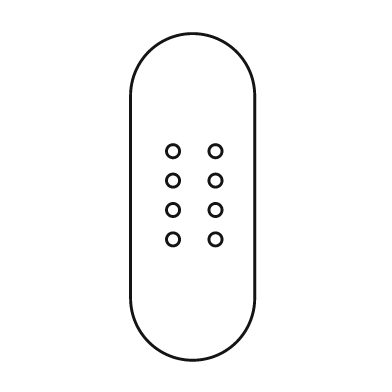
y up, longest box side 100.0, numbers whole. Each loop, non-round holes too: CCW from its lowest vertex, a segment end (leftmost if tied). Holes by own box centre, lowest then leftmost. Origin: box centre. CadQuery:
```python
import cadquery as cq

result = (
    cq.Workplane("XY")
    .moveTo(-19.0, -31.0)
    .threePointArc((0.0, -50.0), (19.0, -31.0))
    .lineTo(19.0, 31.0)
    .threePointArc((0.0, 50.0), (-19.0, 31.0))
    .close()
    .moveTo(-6.0, -13.0)
    .circle(2.0)
    .moveTo(7.0, -13.0)
    .circle(2.0)
    .moveTo(-6.0, -4.0)
    .circle(2.0)
    .moveTo(7.0, -4.0)
    .circle(2.0)
    .moveTo(-6.0, 5.0)
    .circle(2.0)
    .moveTo(7.0, 5.0)
    .circle(2.0)
    .moveTo(-6.0, 14.0)
    .circle(2.0)
    .moveTo(7.0, 14.0)
    .circle(2.0)
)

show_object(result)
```